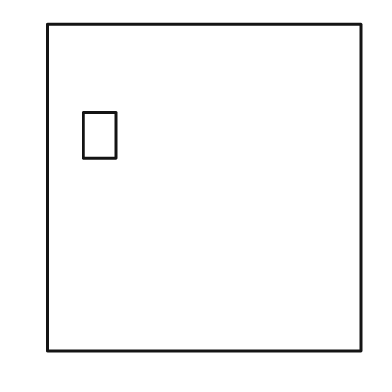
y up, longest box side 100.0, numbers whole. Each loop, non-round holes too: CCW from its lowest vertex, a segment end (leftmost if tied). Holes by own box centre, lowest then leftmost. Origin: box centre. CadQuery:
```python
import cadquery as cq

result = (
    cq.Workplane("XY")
    .moveTo(-48.0, -50.0)
    .lineTo(48.0, -50.0)
    .lineTo(48.0, 50.0)
    .lineTo(-48.0, 50.0)
    .close()
    .moveTo(-37.0, 9.0)
    .lineTo(-27.0, 9.0)
    .lineTo(-27.0, 23.0)
    .lineTo(-37.0, 23.0)
    .close()
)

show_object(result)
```